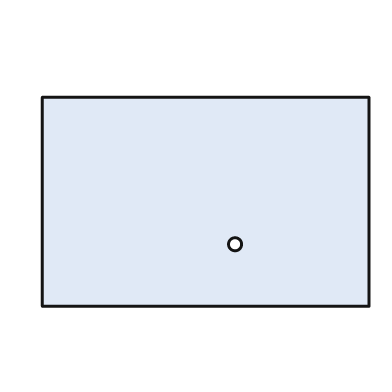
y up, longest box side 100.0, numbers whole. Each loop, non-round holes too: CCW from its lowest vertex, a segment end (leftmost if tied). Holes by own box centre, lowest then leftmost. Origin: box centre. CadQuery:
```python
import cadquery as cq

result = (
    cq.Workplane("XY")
    .moveTo(-50.0, -32.0)
    .lineTo(50.0, -32.0)
    .lineTo(50.0, 32.0)
    .lineTo(-50.0, 32.0)
    .close()
    .moveTo(9.0, -13.0)
    .circle(2.0)
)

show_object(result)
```